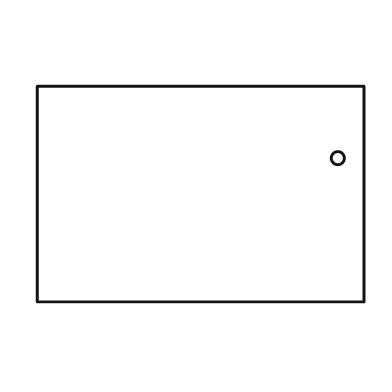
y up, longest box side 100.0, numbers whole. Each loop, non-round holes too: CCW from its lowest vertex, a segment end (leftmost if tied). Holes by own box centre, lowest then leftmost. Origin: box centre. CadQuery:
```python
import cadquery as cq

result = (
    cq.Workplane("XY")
    .moveTo(-50.0, -33.0)
    .lineTo(50.0, -33.0)
    .lineTo(50.0, 33.0)
    .lineTo(-50.0, 33.0)
    .close()
    .moveTo(42.0, 11.0)
    .circle(2.0)
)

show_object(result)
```